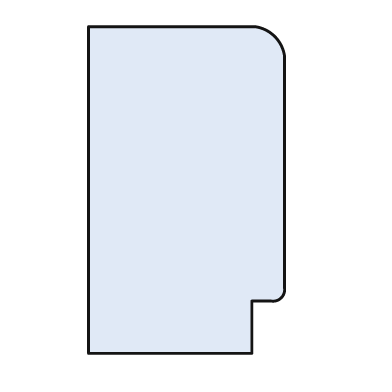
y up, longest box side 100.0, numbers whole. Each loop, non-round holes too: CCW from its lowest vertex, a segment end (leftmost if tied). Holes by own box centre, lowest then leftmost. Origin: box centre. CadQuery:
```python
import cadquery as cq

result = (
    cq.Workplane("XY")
    .moveTo(-30.0, -50.0)
    .lineTo(20.0, -50.0)
    .lineTo(20.0, -34.0)
    .lineTo(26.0, -34.0)
    .threePointArc((29.0, -33.0), (30.0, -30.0))
    .lineTo(30.0, 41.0)
    .threePointArc((27.0, 47.0), (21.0, 50.0))
    .lineTo(-30.0, 50.0)
    .close()
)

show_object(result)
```